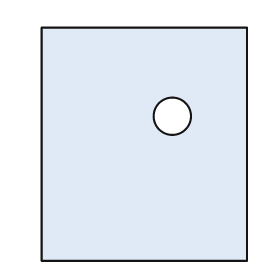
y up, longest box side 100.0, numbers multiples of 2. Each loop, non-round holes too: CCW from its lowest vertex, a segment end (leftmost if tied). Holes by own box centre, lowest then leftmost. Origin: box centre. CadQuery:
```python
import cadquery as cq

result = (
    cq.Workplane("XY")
    .moveTo(-44.0, -50.0)
    .lineTo(44.0, -50.0)
    .lineTo(44.0, 50.0)
    .lineTo(-44.0, 50.0)
    .close()
    .moveTo(12.0, 12.0)
    .circle(8.0)
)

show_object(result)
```